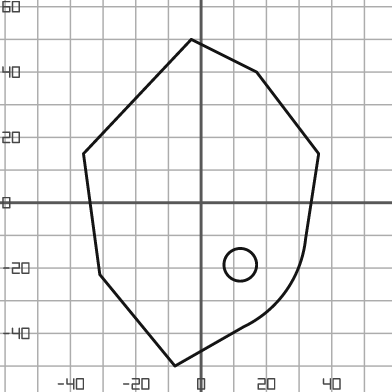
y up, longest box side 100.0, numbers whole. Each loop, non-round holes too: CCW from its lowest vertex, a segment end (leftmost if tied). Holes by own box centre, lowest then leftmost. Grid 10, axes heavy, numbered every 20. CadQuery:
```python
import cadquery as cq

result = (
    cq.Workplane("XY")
    .moveTo(-8.0, -50.0)
    .lineTo(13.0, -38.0)
    .threePointArc((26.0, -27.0), (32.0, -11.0))
    .lineTo(36.0, 15.0)
    .lineTo(17.0, 40.0)
    .lineTo(-3.0, 50.0)
    .lineTo(-36.0, 15.0)
    .lineTo(-31.0, -22.0)
    .close()
    .moveTo(12.0, -19.0)
    .circle(5.0)
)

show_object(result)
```